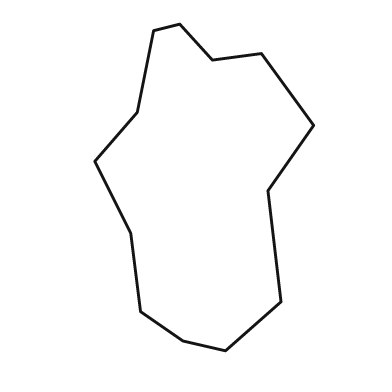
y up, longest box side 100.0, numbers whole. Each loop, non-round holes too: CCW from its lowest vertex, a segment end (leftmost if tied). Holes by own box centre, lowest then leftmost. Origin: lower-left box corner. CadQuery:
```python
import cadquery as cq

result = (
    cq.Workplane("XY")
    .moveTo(40.0, 0.0)
    .lineTo(57.0, 15.0)
    .lineTo(53.0, 49.0)
    .lineTo(67.0, 69.0)
    .lineTo(51.0, 91.0)
    .lineTo(36.0, 89.0)
    .lineTo(26.0, 100.0)
    .lineTo(18.0, 98.0)
    .lineTo(13.0, 73.0)
    .lineTo(0.0, 58.0)
    .lineTo(11.0, 36.0)
    .lineTo(14.0, 12.0)
    .lineTo(27.0, 3.0)
    .close()
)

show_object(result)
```